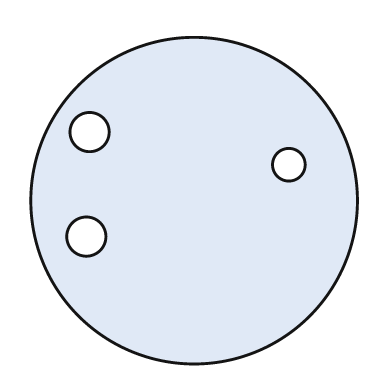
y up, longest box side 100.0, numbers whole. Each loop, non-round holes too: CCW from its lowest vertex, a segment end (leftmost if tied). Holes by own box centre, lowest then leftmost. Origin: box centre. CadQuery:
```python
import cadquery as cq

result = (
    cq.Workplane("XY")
    .moveTo(0.0, 0.0)
    .circle(50.0)
    .moveTo(-33.0, -11.0)
    .circle(6.0)
    .moveTo(29.0, 11.0)
    .circle(5.0)
    .moveTo(-32.0, 21.0)
    .circle(6.0)
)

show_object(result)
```